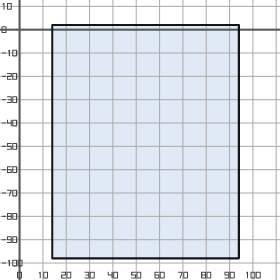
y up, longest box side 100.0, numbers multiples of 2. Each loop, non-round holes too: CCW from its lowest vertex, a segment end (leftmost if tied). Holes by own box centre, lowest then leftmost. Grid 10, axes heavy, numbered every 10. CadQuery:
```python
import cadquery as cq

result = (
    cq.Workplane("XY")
    .moveTo(14.0, -98.0)
    .lineTo(94.0, -98.0)
    .lineTo(94.0, 2.0)
    .lineTo(14.0, 2.0)
    .close()
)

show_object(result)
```